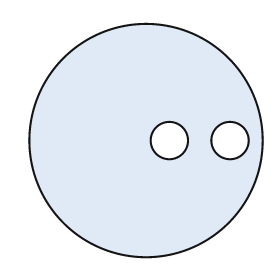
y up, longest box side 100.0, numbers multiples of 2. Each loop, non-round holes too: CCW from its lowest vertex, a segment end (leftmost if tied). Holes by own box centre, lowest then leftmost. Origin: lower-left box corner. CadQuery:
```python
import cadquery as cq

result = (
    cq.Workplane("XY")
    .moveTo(50.0, 50.0)
    .circle(50.0)
    .moveTo(60.0, 50.0)
    .circle(8.0)
    .moveTo(86.0, 50.0)
    .circle(8.0)
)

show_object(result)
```